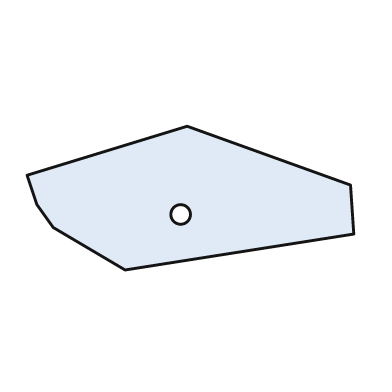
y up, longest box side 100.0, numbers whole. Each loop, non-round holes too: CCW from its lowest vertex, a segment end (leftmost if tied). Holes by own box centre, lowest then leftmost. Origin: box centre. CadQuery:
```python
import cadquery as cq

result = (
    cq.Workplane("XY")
    .moveTo(-20.0, -22.0)
    .lineTo(50.0, -11.0)
    .lineTo(49.0, 4.0)
    .lineTo(-1.0, 22.0)
    .lineTo(-50.0, 7.0)
    .lineTo(-47.0, -2.0)
    .lineTo(-42.0, -9.0)
    .close()
    .moveTo(-3.0, -5.0)
    .circle(3.0)
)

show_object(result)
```